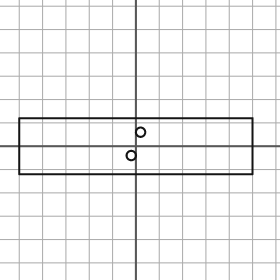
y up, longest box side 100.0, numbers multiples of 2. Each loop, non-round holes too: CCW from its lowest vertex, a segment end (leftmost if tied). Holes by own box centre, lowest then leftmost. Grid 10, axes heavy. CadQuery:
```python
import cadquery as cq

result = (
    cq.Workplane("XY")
    .moveTo(-50.0, -12.0)
    .lineTo(50.0, -12.0)
    .lineTo(50.0, 12.0)
    .lineTo(-50.0, 12.0)
    .close()
    .moveTo(-2.0, -4.0)
    .circle(2.0)
    .moveTo(2.0, 6.0)
    .circle(2.0)
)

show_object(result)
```